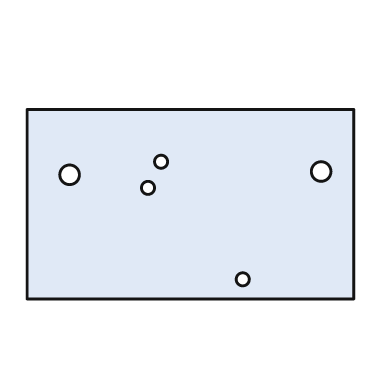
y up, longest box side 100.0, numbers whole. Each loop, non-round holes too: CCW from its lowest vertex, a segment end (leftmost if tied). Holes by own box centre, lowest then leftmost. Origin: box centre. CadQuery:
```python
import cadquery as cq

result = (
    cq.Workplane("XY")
    .moveTo(-50.0, -29.0)
    .lineTo(50.0, -29.0)
    .lineTo(50.0, 29.0)
    .lineTo(-50.0, 29.0)
    .close()
    .moveTo(16.0, -23.0)
    .circle(2.0)
    .moveTo(-13.0, 5.0)
    .circle(2.0)
    .moveTo(-37.0, 9.0)
    .circle(3.0)
    .moveTo(40.0, 10.0)
    .circle(3.0)
    .moveTo(-9.0, 13.0)
    .circle(2.0)
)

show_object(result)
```